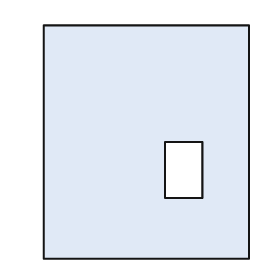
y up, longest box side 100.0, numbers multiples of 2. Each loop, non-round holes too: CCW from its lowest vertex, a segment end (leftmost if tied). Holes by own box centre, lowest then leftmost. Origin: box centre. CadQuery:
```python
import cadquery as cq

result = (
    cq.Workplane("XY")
    .moveTo(-44.0, -50.0)
    .lineTo(44.0, -50.0)
    .lineTo(44.0, 50.0)
    .lineTo(-44.0, 50.0)
    .close()
    .moveTo(8.0, -24.0)
    .lineTo(24.0, -24.0)
    .lineTo(24.0, 0.0)
    .lineTo(8.0, 0.0)
    .close()
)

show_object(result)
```